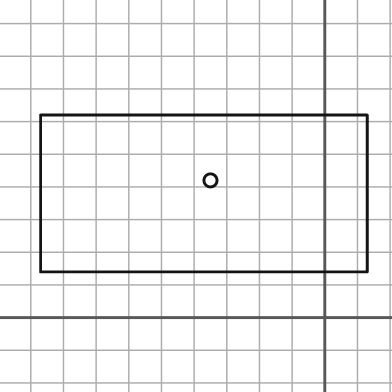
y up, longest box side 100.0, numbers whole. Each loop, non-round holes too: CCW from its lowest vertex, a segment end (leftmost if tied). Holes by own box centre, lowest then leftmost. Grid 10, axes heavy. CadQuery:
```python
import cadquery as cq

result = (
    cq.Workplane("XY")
    .moveTo(-87.0, 14.0)
    .lineTo(13.0, 14.0)
    .lineTo(13.0, 62.0)
    .lineTo(-87.0, 62.0)
    .close()
    .moveTo(-35.0, 42.0)
    .circle(2.0)
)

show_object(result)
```